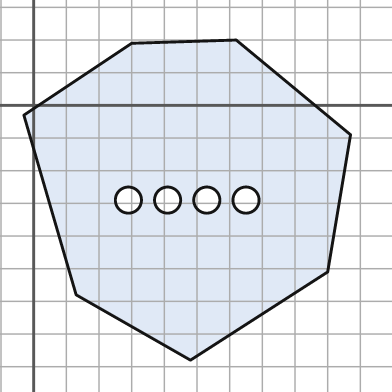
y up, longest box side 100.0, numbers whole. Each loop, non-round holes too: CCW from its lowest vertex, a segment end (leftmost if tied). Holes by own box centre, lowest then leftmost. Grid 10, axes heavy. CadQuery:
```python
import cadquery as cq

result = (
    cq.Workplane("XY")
    .moveTo(48.0, -78.0)
    .lineTo(90.0, -51.0)
    .lineTo(97.0, -9.0)
    .lineTo(62.0, 20.0)
    .lineTo(30.0, 19.0)
    .lineTo(-3.0, -3.0)
    .lineTo(13.0, -58.0)
    .close()
    .moveTo(29.0, -29.0)
    .circle(4.0)
    .moveTo(41.0, -29.0)
    .circle(4.0)
    .moveTo(53.0, -29.0)
    .circle(4.0)
    .moveTo(65.0, -29.0)
    .circle(4.0)
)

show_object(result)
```